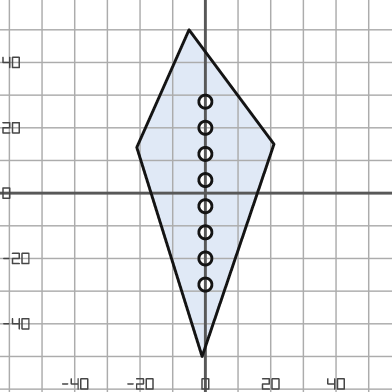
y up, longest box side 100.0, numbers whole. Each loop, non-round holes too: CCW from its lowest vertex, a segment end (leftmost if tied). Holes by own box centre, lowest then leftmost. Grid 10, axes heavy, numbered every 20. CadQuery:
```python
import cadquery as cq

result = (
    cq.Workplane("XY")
    .moveTo(-1.0, -50.0)
    .lineTo(21.0, 15.0)
    .lineTo(-5.0, 50.0)
    .lineTo(-21.0, 14.0)
    .close()
    .moveTo(0.0, -28.0)
    .circle(2.0)
    .moveTo(0.0, -20.0)
    .circle(2.0)
    .moveTo(0.0, -12.0)
    .circle(2.0)
    .moveTo(0.0, -4.0)
    .circle(2.0)
    .moveTo(0.0, 4.0)
    .circle(2.0)
    .moveTo(0.0, 12.0)
    .circle(2.0)
    .moveTo(0.0, 20.0)
    .circle(2.0)
    .moveTo(0.0, 28.0)
    .circle(2.0)
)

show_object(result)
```